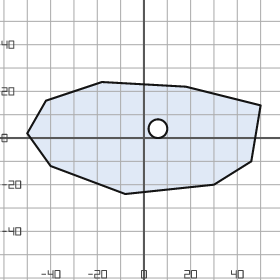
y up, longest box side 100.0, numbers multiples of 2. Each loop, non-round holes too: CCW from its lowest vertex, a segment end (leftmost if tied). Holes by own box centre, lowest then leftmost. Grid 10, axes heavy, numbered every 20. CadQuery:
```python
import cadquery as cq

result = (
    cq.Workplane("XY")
    .moveTo(-8.0, -24.0)
    .lineTo(30.0, -20.0)
    .lineTo(46.0, -10.0)
    .lineTo(50.0, 14.0)
    .lineTo(18.0, 22.0)
    .lineTo(-18.0, 24.0)
    .lineTo(-42.0, 16.0)
    .lineTo(-50.0, 2.0)
    .lineTo(-40.0, -12.0)
    .close()
    .moveTo(6.0, 4.0)
    .circle(4.0)
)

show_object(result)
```